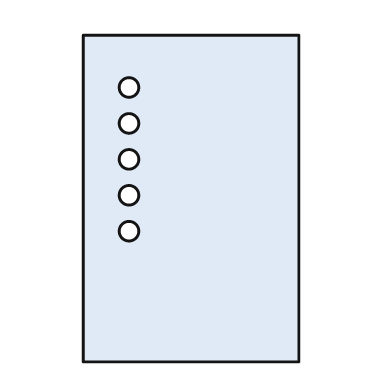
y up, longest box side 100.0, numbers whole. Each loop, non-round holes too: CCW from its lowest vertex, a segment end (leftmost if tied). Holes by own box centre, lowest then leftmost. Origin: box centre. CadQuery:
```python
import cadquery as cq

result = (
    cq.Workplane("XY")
    .moveTo(-33.0, -50.0)
    .lineTo(33.0, -50.0)
    .lineTo(33.0, 50.0)
    .lineTo(-33.0, 50.0)
    .close()
    .moveTo(-19.0, -10.0)
    .circle(3.0)
    .moveTo(-19.0, 1.0)
    .circle(3.0)
    .moveTo(-19.0, 12.0)
    .circle(3.0)
    .moveTo(-19.0, 23.0)
    .circle(3.0)
    .moveTo(-19.0, 34.0)
    .circle(3.0)
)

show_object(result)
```